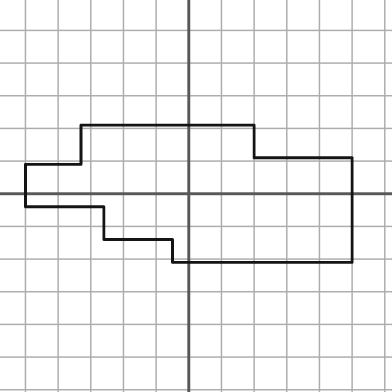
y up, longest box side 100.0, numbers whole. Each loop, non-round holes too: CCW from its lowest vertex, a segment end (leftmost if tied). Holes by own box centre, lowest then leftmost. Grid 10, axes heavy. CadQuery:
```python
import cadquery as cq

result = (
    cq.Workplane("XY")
    .moveTo(-5.0, -21.0)
    .lineTo(50.0, -21.0)
    .lineTo(50.0, 11.0)
    .lineTo(20.0, 11.0)
    .lineTo(20.0, 21.0)
    .lineTo(-33.0, 21.0)
    .lineTo(-33.0, 9.0)
    .lineTo(-50.0, 9.0)
    .lineTo(-50.0, -4.0)
    .lineTo(-26.0, -4.0)
    .lineTo(-26.0, -14.0)
    .lineTo(-5.0, -14.0)
    .close()
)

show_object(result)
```